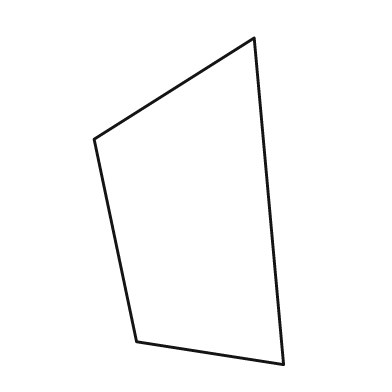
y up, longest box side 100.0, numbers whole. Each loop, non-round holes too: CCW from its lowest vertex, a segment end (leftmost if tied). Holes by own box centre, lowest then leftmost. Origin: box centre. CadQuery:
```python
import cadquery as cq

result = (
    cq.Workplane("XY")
    .moveTo(29.0, -50.0)
    .lineTo(20.0, 50.0)
    .lineTo(-29.0, 19.0)
    .lineTo(-16.0, -43.0)
    .close()
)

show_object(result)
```